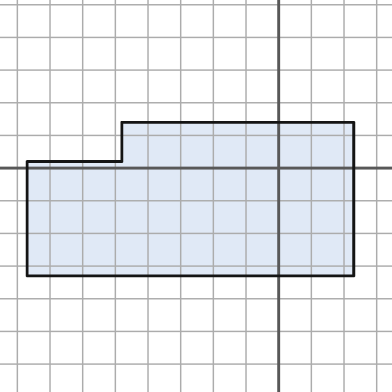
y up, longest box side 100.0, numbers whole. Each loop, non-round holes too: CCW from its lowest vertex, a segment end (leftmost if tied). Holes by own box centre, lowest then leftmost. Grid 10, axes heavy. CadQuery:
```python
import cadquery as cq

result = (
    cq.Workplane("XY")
    .moveTo(-77.0, -33.0)
    .lineTo(23.0, -33.0)
    .lineTo(23.0, 14.0)
    .lineTo(-48.0, 14.0)
    .lineTo(-48.0, 2.0)
    .lineTo(-77.0, 2.0)
    .close()
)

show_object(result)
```